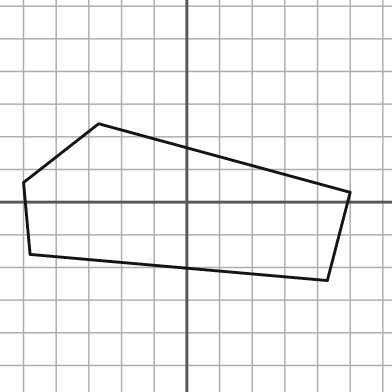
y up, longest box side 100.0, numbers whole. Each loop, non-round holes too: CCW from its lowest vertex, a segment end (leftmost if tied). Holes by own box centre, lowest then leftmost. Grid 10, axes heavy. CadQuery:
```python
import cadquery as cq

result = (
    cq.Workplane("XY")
    .moveTo(43.0, -24.0)
    .lineTo(50.0, 3.0)
    .lineTo(-27.0, 24.0)
    .lineTo(-50.0, 6.0)
    .lineTo(-48.0, -16.0)
    .close()
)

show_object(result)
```